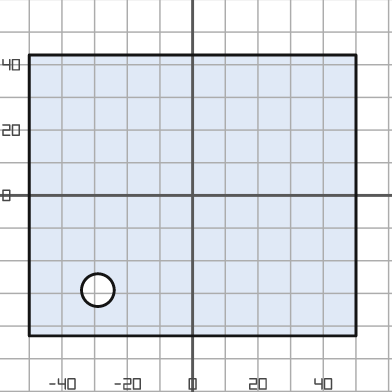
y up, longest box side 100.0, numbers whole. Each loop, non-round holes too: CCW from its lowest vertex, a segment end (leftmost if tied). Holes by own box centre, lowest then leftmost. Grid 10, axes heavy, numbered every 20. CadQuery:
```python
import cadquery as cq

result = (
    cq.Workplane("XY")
    .moveTo(-50.0, -43.0)
    .lineTo(50.0, -43.0)
    .lineTo(50.0, 43.0)
    .lineTo(-50.0, 43.0)
    .close()
    .moveTo(-29.0, -29.0)
    .circle(5.0)
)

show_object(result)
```